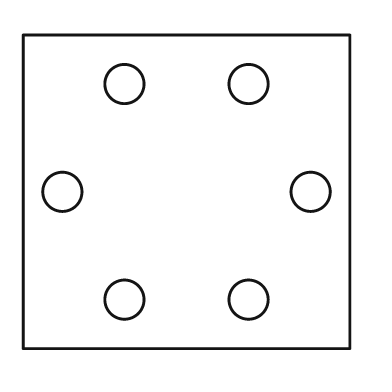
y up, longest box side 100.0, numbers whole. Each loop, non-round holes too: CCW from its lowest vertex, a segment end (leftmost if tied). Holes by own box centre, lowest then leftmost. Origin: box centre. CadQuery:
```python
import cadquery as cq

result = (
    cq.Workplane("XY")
    .moveTo(-50.0, -48.0)
    .lineTo(50.0, -48.0)
    .lineTo(50.0, 48.0)
    .lineTo(-50.0, 48.0)
    .close()
    .moveTo(-19.0, -33.0)
    .circle(6.0)
    .moveTo(19.0, -33.0)
    .circle(6.0)
    .moveTo(-38.0, 0.0)
    .circle(6.0)
    .moveTo(38.0, 0.0)
    .circle(6.0)
    .moveTo(-19.0, 33.0)
    .circle(6.0)
    .moveTo(19.0, 33.0)
    .circle(6.0)
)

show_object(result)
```